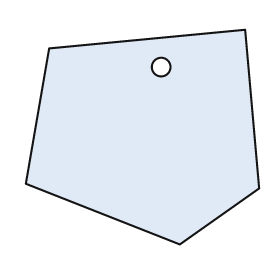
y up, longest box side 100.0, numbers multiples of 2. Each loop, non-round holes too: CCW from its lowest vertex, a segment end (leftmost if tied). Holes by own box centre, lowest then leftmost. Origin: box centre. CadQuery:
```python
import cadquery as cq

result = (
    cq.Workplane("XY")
    .moveTo(16.0, -46.0)
    .lineTo(50.0, -22.0)
    .lineTo(44.0, 46.0)
    .lineTo(-40.0, 38.0)
    .lineTo(-50.0, -20.0)
    .close()
    .moveTo(8.0, 30.0)
    .circle(4.0)
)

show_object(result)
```